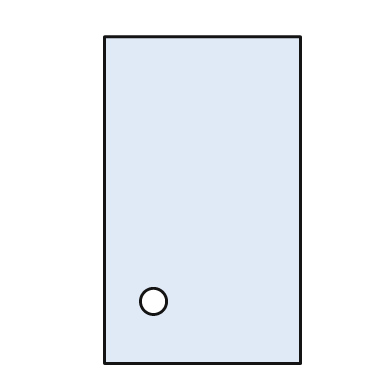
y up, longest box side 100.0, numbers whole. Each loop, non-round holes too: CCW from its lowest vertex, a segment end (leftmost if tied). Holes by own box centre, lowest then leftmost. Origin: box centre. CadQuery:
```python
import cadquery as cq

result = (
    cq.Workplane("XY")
    .moveTo(-30.0, -50.0)
    .lineTo(30.0, -50.0)
    .lineTo(30.0, 50.0)
    .lineTo(-30.0, 50.0)
    .close()
    .moveTo(-15.0, -31.0)
    .circle(4.0)
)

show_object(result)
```